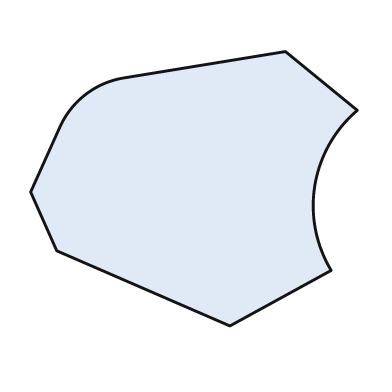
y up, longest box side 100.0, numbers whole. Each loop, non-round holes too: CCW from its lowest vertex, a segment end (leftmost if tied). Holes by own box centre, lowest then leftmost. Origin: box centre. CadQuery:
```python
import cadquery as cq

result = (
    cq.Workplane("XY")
    .moveTo(11.0, -42.0)
    .lineTo(42.0, -25.0)
    .threePointArc((37.0, 1.0), (50.0, 24.0))
    .lineTo(28.0, 42.0)
    .lineTo(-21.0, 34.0)
    .threePointArc((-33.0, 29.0), (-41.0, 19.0))
    .lineTo(-50.0, -1.0)
    .lineTo(-42.0, -19.0)
    .close()
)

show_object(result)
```